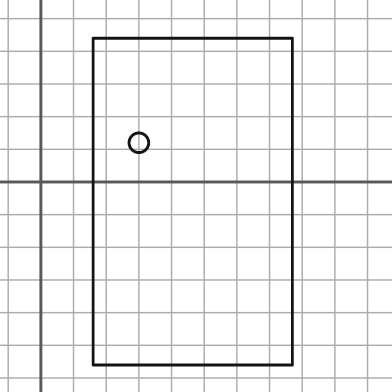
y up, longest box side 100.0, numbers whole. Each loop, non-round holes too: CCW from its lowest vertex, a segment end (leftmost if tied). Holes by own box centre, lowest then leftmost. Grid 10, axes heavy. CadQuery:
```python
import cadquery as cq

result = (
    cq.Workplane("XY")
    .moveTo(16.0, -56.0)
    .lineTo(77.0, -56.0)
    .lineTo(77.0, 44.0)
    .lineTo(16.0, 44.0)
    .close()
    .moveTo(30.0, 12.0)
    .circle(3.0)
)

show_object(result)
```